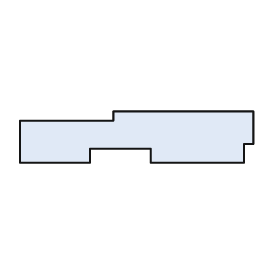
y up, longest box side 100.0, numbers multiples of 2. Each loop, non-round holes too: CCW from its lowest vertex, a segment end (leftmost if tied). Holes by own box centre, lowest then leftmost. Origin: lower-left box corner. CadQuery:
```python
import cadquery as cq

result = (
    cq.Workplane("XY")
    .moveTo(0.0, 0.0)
    .lineTo(30.0, 0.0)
    .lineTo(30.0, 6.0)
    .lineTo(56.0, 6.0)
    .lineTo(56.0, 0.0)
    .lineTo(96.0, 0.0)
    .lineTo(96.0, 8.0)
    .lineTo(100.0, 8.0)
    .lineTo(100.0, 22.0)
    .lineTo(40.0, 22.0)
    .lineTo(40.0, 18.0)
    .lineTo(0.0, 18.0)
    .close()
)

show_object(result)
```